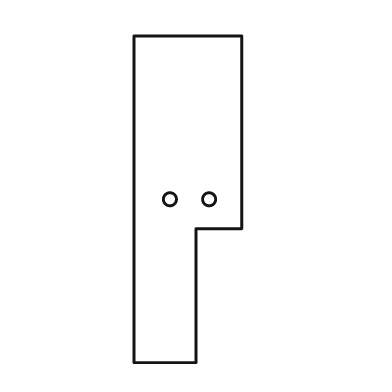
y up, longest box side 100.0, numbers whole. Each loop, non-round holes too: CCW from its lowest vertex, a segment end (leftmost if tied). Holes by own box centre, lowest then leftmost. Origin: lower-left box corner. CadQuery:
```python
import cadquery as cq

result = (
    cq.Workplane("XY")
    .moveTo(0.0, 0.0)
    .lineTo(19.0, 0.0)
    .lineTo(19.0, 41.0)
    .lineTo(33.0, 41.0)
    .lineTo(33.0, 100.0)
    .lineTo(0.0, 100.0)
    .close()
    .moveTo(11.0, 50.0)
    .circle(2.0)
    .moveTo(23.0, 50.0)
    .circle(2.0)
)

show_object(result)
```